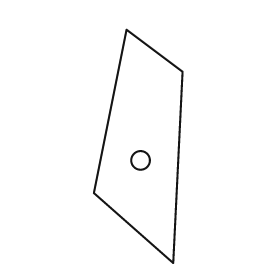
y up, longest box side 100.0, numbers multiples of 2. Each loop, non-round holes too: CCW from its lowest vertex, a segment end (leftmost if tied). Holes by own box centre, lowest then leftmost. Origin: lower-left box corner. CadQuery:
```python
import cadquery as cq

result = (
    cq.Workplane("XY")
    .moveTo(34.0, 0.0)
    .lineTo(38.0, 82.0)
    .lineTo(14.0, 100.0)
    .lineTo(0.0, 30.0)
    .close()
    .moveTo(20.0, 44.0)
    .circle(4.0)
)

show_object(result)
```